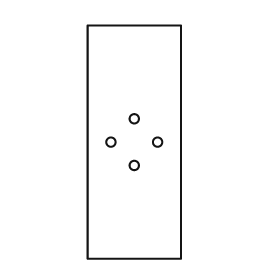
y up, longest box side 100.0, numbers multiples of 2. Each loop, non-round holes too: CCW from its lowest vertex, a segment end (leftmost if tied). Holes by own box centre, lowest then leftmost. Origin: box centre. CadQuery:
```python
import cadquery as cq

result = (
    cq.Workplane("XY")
    .moveTo(-20.0, -50.0)
    .lineTo(20.0, -50.0)
    .lineTo(20.0, 50.0)
    .lineTo(-20.0, 50.0)
    .close()
    .moveTo(0.0, -10.0)
    .circle(2.0)
    .moveTo(-10.0, 0.0)
    .circle(2.0)
    .moveTo(10.0, 0.0)
    .circle(2.0)
    .moveTo(0.0, 10.0)
    .circle(2.0)
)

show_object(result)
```